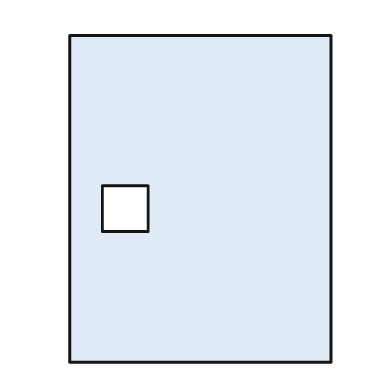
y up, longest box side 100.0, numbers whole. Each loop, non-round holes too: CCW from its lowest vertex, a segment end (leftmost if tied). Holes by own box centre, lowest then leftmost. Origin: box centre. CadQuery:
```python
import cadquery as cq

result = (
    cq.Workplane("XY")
    .moveTo(-40.0, -50.0)
    .lineTo(40.0, -50.0)
    .lineTo(40.0, 50.0)
    .lineTo(-40.0, 50.0)
    .close()
    .moveTo(-30.0, -10.0)
    .lineTo(-16.0, -10.0)
    .lineTo(-16.0, 4.0)
    .lineTo(-30.0, 4.0)
    .close()
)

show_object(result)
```